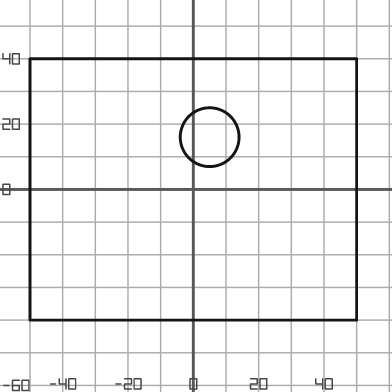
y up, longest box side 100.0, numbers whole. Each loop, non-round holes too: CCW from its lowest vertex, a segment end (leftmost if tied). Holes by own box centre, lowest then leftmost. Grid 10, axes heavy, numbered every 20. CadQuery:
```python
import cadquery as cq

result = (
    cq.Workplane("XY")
    .moveTo(-50.0, -40.0)
    .lineTo(50.0, -40.0)
    .lineTo(50.0, 40.0)
    .lineTo(-50.0, 40.0)
    .close()
    .moveTo(5.0, 16.0)
    .circle(9.0)
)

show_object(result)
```